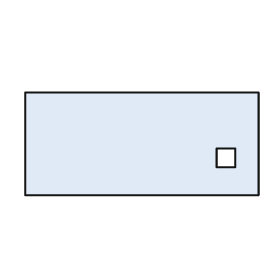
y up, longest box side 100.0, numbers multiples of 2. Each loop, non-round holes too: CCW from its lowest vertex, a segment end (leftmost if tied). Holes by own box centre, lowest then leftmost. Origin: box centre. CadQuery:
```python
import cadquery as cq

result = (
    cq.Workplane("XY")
    .moveTo(-50.0, -22.0)
    .lineTo(50.0, -22.0)
    .lineTo(50.0, 22.0)
    .lineTo(-50.0, 22.0)
    .close()
    .moveTo(32.0, -10.0)
    .lineTo(40.0, -10.0)
    .lineTo(40.0, -2.0)
    .lineTo(32.0, -2.0)
    .close()
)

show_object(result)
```